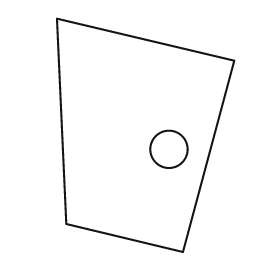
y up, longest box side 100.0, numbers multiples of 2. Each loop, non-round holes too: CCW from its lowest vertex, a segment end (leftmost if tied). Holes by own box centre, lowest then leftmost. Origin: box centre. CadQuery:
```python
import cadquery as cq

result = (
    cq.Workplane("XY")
    .moveTo(16.0, -50.0)
    .lineTo(38.0, 32.0)
    .lineTo(-38.0, 50.0)
    .lineTo(-34.0, -38.0)
    .close()
    .moveTo(10.0, -6.0)
    .circle(8.0)
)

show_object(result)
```